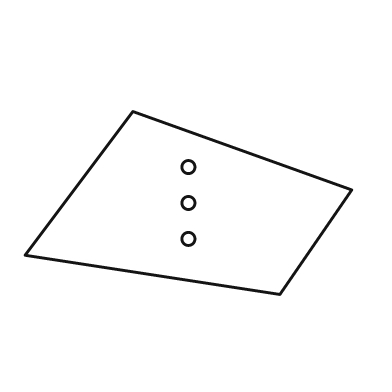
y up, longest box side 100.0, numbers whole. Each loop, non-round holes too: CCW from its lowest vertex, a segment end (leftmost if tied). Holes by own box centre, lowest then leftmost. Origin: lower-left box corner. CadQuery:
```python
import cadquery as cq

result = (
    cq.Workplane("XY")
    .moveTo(78.0, 0.0)
    .lineTo(100.0, 32.0)
    .lineTo(33.0, 56.0)
    .lineTo(0.0, 12.0)
    .close()
    .moveTo(50.0, 17.0)
    .circle(2.0)
    .moveTo(50.0, 28.0)
    .circle(2.0)
    .moveTo(50.0, 39.0)
    .circle(2.0)
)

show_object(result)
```